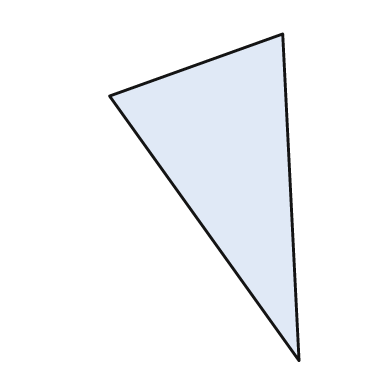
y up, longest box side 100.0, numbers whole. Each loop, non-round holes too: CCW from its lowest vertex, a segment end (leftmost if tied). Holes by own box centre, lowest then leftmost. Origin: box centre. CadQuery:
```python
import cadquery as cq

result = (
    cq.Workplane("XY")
    .moveTo(29.0, -50.0)
    .lineTo(24.0, 50.0)
    .lineTo(-29.0, 31.0)
    .close()
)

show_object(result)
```